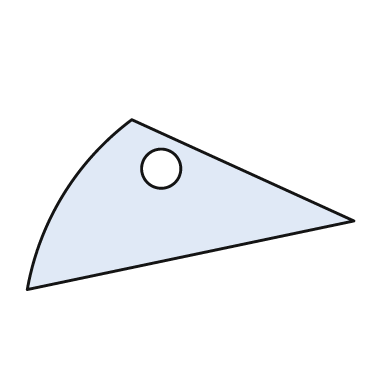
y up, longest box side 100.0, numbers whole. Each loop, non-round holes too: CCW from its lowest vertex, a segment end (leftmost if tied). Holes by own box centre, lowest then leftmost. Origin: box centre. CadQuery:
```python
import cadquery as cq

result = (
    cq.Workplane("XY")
    .moveTo(-50.0, -26.0)
    .lineTo(50.0, -5.0)
    .lineTo(-18.0, 26.0)
    .threePointArc((-39.0, 3.0), (-50.0, -26.0))
    .close()
    .moveTo(-9.0, 11.0)
    .circle(6.0)
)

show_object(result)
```